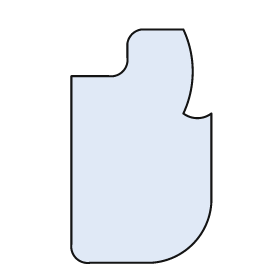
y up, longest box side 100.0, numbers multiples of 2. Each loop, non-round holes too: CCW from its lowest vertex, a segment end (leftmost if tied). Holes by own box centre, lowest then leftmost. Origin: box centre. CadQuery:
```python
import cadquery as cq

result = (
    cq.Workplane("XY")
    .moveTo(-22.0, -50.0)
    .lineTo(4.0, -50.0)
    .threePointArc((22.0, -42.0), (30.0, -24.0))
    .lineTo(30.0, 14.0)
    .threePointArc((24.0, 12.0), (18.0, 14.0))
    .threePointArc((22.0, 32.0), (18.0, 50.0))
    .lineTo(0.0, 50.0)
    .threePointArc((-4.0, 48.0), (-6.0, 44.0))
    .lineTo(-6.0, 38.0)
    .threePointArc((-8.0, 32.0), (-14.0, 30.0))
    .lineTo(-30.0, 30.0)
    .lineTo(-30.0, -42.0)
    .threePointArc((-28.0, -48.0), (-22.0, -50.0))
    .close()
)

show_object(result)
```